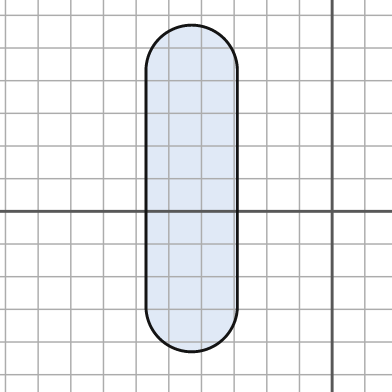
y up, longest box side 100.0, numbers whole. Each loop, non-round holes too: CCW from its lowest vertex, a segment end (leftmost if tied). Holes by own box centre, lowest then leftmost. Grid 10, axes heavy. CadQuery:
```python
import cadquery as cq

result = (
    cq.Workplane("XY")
    .moveTo(-57.0, -29.0)
    .threePointArc((-43.0, -43.0), (-29.0, -29.0))
    .lineTo(-29.0, 43.0)
    .threePointArc((-43.0, 57.0), (-57.0, 43.0))
    .close()
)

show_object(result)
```